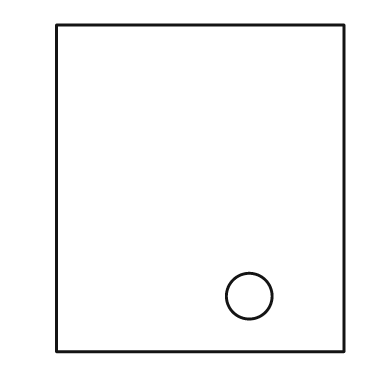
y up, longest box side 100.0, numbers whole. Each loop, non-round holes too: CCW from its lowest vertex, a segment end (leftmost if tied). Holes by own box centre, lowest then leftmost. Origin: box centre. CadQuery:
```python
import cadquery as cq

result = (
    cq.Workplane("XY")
    .moveTo(-44.0, -50.0)
    .lineTo(44.0, -50.0)
    .lineTo(44.0, 50.0)
    .lineTo(-44.0, 50.0)
    .close()
    .moveTo(15.0, -33.0)
    .circle(7.0)
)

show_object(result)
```